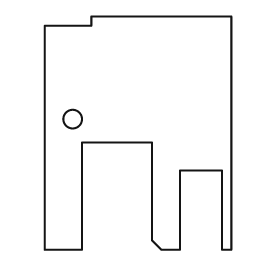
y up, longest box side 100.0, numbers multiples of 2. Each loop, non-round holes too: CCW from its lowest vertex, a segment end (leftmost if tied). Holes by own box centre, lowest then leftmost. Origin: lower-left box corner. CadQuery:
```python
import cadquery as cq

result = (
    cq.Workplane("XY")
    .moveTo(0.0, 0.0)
    .lineTo(16.0, 0.0)
    .lineTo(16.0, 46.0)
    .lineTo(46.0, 46.0)
    .lineTo(46.0, 4.0)
    .lineTo(50.0, 0.0)
    .lineTo(58.0, 0.0)
    .lineTo(58.0, 34.0)
    .lineTo(76.0, 34.0)
    .lineTo(76.0, 0.0)
    .lineTo(80.0, 0.0)
    .lineTo(80.0, 100.0)
    .lineTo(20.0, 100.0)
    .lineTo(20.0, 96.0)
    .lineTo(0.0, 96.0)
    .close()
    .moveTo(12.0, 56.0)
    .circle(4.0)
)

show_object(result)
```